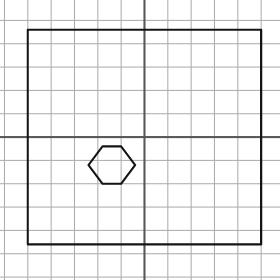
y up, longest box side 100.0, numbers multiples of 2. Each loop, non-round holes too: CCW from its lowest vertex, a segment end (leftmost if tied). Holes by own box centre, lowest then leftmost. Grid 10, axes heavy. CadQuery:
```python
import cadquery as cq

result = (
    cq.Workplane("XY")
    .moveTo(-50.0, -46.0)
    .lineTo(50.0, -46.0)
    .lineTo(50.0, 46.0)
    .lineTo(-50.0, 46.0)
    .close()
    .moveTo(-18.0, -20.0)
    .lineTo(-10.0, -20.0)
    .lineTo(-4.0, -12.0)
    .lineTo(-10.0, -4.0)
    .lineTo(-18.0, -4.0)
    .lineTo(-24.0, -12.0)
    .close()
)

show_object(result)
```